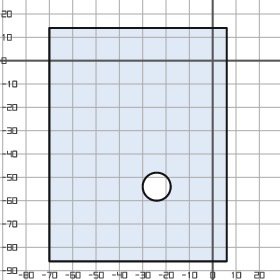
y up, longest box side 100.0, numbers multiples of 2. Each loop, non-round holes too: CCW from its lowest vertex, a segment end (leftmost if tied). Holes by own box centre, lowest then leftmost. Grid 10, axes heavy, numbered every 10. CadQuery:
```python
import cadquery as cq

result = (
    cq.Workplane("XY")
    .moveTo(-70.0, -86.0)
    .lineTo(6.0, -86.0)
    .lineTo(6.0, 14.0)
    .lineTo(-70.0, 14.0)
    .close()
    .moveTo(-24.0, -54.0)
    .circle(6.0)
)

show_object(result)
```